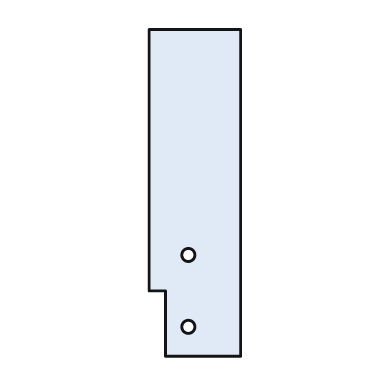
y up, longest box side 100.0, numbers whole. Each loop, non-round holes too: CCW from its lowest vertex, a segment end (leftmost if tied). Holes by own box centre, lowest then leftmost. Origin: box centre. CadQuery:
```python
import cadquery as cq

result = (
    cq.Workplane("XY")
    .moveTo(-9.0, -50.0)
    .lineTo(14.0, -50.0)
    .lineTo(14.0, 50.0)
    .lineTo(-14.0, 50.0)
    .lineTo(-14.0, -30.0)
    .lineTo(-9.0, -30.0)
    .close()
    .moveTo(-2.0, -41.0)
    .circle(2.0)
    .moveTo(-2.0, -19.0)
    .circle(2.0)
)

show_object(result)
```